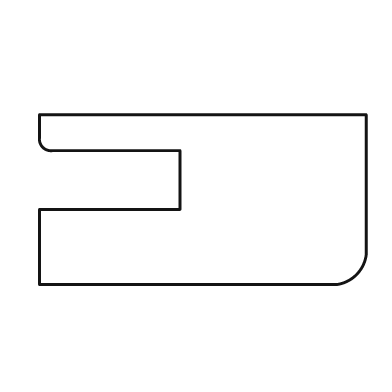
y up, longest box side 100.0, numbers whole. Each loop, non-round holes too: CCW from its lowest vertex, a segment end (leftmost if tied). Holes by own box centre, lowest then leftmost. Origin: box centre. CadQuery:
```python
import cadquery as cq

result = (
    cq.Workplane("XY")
    .moveTo(-50.0, -26.0)
    .lineTo(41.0, -26.0)
    .threePointArc((47.0, -23.0), (50.0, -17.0))
    .lineTo(50.0, 26.0)
    .lineTo(-50.0, 26.0)
    .lineTo(-50.0, 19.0)
    .threePointArc((-49.0, 16.0), (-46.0, 15.0))
    .lineTo(-7.0, 15.0)
    .lineTo(-7.0, -3.0)
    .lineTo(-50.0, -3.0)
    .close()
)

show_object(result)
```